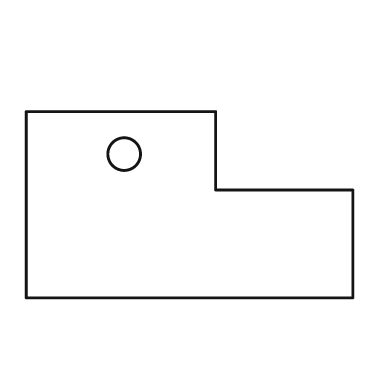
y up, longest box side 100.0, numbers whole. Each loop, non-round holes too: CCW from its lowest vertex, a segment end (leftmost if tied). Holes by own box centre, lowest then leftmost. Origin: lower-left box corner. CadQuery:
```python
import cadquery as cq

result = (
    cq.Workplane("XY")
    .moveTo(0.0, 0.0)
    .lineTo(100.0, 0.0)
    .lineTo(100.0, 33.0)
    .lineTo(58.0, 33.0)
    .lineTo(58.0, 57.0)
    .lineTo(0.0, 57.0)
    .close()
    .moveTo(30.0, 44.0)
    .circle(5.0)
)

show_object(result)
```